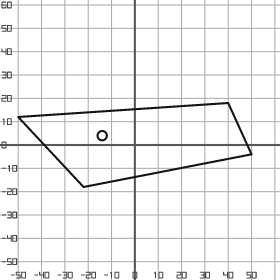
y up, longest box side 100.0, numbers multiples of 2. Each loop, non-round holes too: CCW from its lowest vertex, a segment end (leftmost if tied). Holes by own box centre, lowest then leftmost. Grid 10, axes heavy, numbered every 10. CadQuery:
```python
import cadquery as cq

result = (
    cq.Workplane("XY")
    .moveTo(-22.0, -18.0)
    .lineTo(50.0, -4.0)
    .lineTo(40.0, 18.0)
    .lineTo(-50.0, 12.0)
    .close()
    .moveTo(-14.0, 4.0)
    .circle(2.0)
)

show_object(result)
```